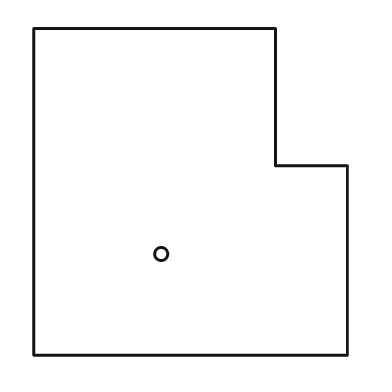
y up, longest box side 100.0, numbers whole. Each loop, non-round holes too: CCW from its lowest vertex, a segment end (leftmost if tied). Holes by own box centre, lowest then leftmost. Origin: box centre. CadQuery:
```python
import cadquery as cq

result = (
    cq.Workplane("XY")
    .moveTo(-48.0, -50.0)
    .lineTo(48.0, -50.0)
    .lineTo(48.0, 8.0)
    .lineTo(26.0, 8.0)
    .lineTo(26.0, 50.0)
    .lineTo(-48.0, 50.0)
    .close()
    .moveTo(-9.0, -19.0)
    .circle(2.0)
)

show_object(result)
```